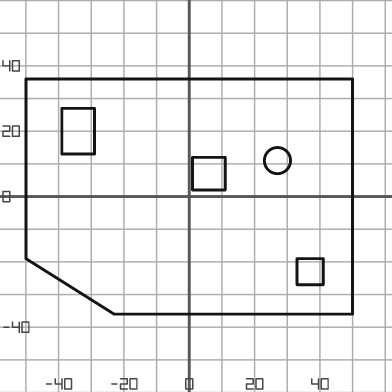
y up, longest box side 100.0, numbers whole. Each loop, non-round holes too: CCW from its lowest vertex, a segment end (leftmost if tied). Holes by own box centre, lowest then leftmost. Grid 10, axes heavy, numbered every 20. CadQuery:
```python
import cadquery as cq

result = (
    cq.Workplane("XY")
    .moveTo(-23.0, -36.0)
    .lineTo(50.0, -36.0)
    .lineTo(50.0, 36.0)
    .lineTo(-50.0, 36.0)
    .lineTo(-50.0, -19.0)
    .close()
    .moveTo(33.0, -27.0)
    .lineTo(41.0, -27.0)
    .lineTo(41.0, -19.0)
    .lineTo(33.0, -19.0)
    .close()
    .moveTo(1.0, 2.0)
    .lineTo(11.0, 2.0)
    .lineTo(11.0, 12.0)
    .lineTo(1.0, 12.0)
    .close()
    .moveTo(27.0, 11.0)
    .circle(4.0)
    .moveTo(-39.0, 13.0)
    .lineTo(-29.0, 13.0)
    .lineTo(-29.0, 27.0)
    .lineTo(-39.0, 27.0)
    .close()
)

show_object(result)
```